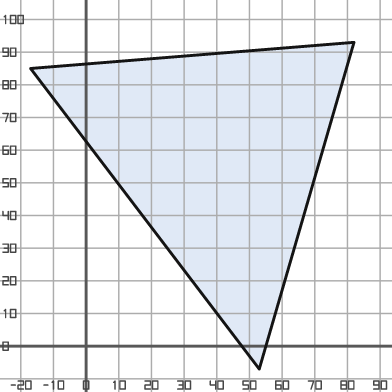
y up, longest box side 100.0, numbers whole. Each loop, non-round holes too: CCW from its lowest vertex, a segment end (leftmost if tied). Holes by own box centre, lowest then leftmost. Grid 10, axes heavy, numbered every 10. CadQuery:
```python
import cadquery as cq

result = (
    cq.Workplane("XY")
    .moveTo(53.0, -7.0)
    .lineTo(82.0, 93.0)
    .lineTo(-17.0, 85.0)
    .close()
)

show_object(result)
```